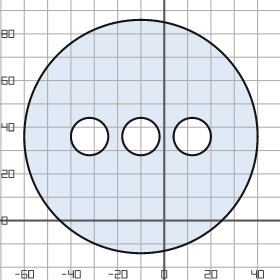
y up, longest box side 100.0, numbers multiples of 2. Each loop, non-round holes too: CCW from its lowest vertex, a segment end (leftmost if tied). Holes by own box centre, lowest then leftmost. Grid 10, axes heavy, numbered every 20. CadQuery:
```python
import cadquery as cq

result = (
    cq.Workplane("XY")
    .moveTo(-10.0, 36.0)
    .circle(50.0)
    .moveTo(-32.0, 36.0)
    .circle(8.0)
    .moveTo(-10.0, 36.0)
    .circle(8.0)
    .moveTo(12.0, 36.0)
    .circle(8.0)
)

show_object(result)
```